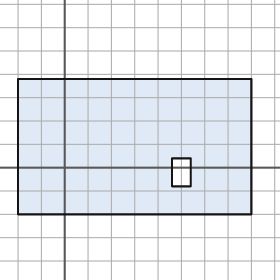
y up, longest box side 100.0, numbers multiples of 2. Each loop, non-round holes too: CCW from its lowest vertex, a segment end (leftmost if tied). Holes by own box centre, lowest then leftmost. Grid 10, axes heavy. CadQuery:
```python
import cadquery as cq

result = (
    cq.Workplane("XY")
    .moveTo(-20.0, -20.0)
    .lineTo(80.0, -20.0)
    .lineTo(80.0, 38.0)
    .lineTo(-20.0, 38.0)
    .close()
    .moveTo(46.0, -8.0)
    .lineTo(54.0, -8.0)
    .lineTo(54.0, 4.0)
    .lineTo(46.0, 4.0)
    .close()
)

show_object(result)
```